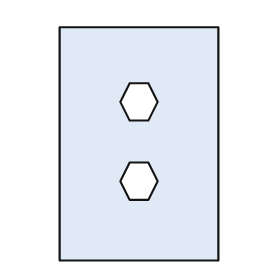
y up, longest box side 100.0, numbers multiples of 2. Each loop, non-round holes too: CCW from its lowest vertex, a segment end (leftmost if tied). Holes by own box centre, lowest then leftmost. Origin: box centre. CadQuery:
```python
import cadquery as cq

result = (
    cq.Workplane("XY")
    .moveTo(-34.0, -50.0)
    .lineTo(34.0, -50.0)
    .lineTo(34.0, 50.0)
    .lineTo(-34.0, 50.0)
    .close()
    .moveTo(-4.0, -24.0)
    .lineTo(4.0, -24.0)
    .lineTo(8.0, -16.0)
    .lineTo(4.0, -8.0)
    .lineTo(-4.0, -8.0)
    .lineTo(-8.0, -16.0)
    .close()
    .moveTo(-4.0, 10.0)
    .lineTo(4.0, 10.0)
    .lineTo(8.0, 18.0)
    .lineTo(4.0, 26.0)
    .lineTo(-4.0, 26.0)
    .lineTo(-8.0, 18.0)
    .close()
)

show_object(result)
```